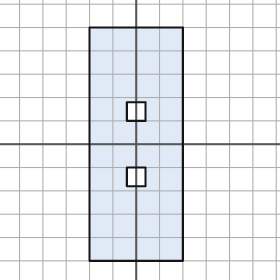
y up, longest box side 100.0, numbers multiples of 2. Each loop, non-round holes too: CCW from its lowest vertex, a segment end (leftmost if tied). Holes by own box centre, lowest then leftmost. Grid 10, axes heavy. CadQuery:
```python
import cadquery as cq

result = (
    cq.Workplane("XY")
    .moveTo(-20.0, -50.0)
    .lineTo(20.0, -50.0)
    .lineTo(20.0, 50.0)
    .lineTo(-20.0, 50.0)
    .close()
    .moveTo(-4.0, -18.0)
    .lineTo(4.0, -18.0)
    .lineTo(4.0, -10.0)
    .lineTo(-4.0, -10.0)
    .close()
    .moveTo(-4.0, 10.0)
    .lineTo(4.0, 10.0)
    .lineTo(4.0, 18.0)
    .lineTo(-4.0, 18.0)
    .close()
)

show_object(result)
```